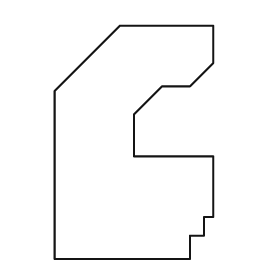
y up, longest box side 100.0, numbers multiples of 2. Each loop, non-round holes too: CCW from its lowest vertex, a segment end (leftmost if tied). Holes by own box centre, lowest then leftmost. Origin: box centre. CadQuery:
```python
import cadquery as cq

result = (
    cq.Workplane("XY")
    .moveTo(-34.0, -50.0)
    .lineTo(24.0, -50.0)
    .lineTo(24.0, -40.0)
    .lineTo(30.0, -40.0)
    .lineTo(30.0, -32.0)
    .lineTo(34.0, -32.0)
    .lineTo(34.0, -6.0)
    .lineTo(0.0, -6.0)
    .lineTo(0.0, 12.0)
    .lineTo(12.0, 24.0)
    .lineTo(24.0, 24.0)
    .lineTo(34.0, 34.0)
    .lineTo(34.0, 50.0)
    .lineTo(-6.0, 50.0)
    .lineTo(-34.0, 22.0)
    .close()
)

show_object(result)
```